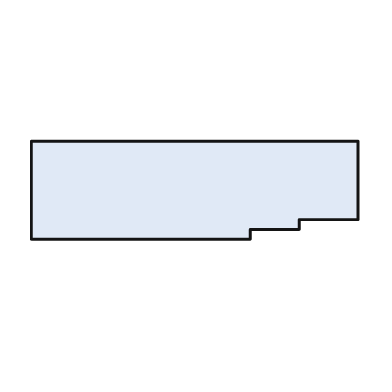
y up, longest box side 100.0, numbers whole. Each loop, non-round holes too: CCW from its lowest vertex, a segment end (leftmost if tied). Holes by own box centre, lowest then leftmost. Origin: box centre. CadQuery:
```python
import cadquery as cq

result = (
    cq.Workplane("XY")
    .moveTo(-50.0, -15.0)
    .lineTo(17.0, -15.0)
    .lineTo(17.0, -12.0)
    .lineTo(32.0, -12.0)
    .lineTo(32.0, -9.0)
    .lineTo(50.0, -9.0)
    .lineTo(50.0, 15.0)
    .lineTo(-50.0, 15.0)
    .close()
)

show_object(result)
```